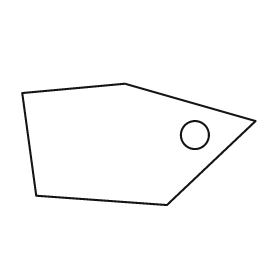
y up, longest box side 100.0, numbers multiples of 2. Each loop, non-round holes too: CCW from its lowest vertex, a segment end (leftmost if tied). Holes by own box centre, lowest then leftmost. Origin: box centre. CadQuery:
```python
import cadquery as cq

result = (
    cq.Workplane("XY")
    .moveTo(12.0, -26.0)
    .lineTo(50.0, 10.0)
    .lineTo(-6.0, 26.0)
    .lineTo(-50.0, 22.0)
    .lineTo(-44.0, -22.0)
    .close()
    .moveTo(24.0, 4.0)
    .circle(6.0)
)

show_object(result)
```